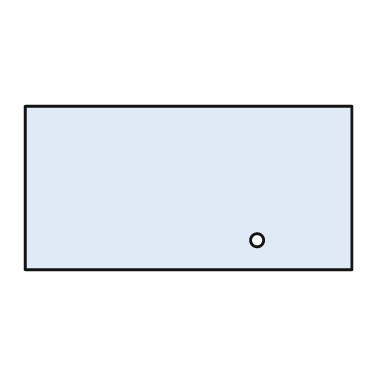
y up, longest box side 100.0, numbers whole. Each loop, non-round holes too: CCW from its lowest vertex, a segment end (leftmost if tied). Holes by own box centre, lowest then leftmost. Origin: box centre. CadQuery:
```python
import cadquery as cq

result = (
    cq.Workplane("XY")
    .moveTo(-50.0, -25.0)
    .lineTo(50.0, -25.0)
    .lineTo(50.0, 25.0)
    .lineTo(-50.0, 25.0)
    .close()
    .moveTo(21.0, -16.0)
    .circle(2.0)
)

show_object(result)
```